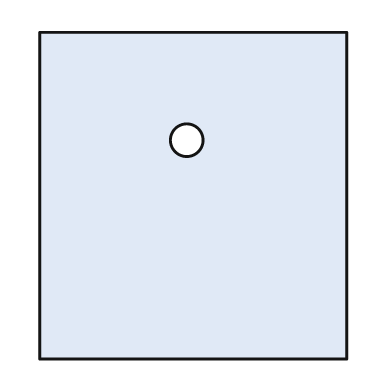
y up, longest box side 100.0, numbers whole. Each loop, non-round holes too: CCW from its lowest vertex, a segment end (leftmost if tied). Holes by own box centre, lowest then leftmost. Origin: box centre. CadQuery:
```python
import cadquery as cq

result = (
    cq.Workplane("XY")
    .moveTo(-47.0, -50.0)
    .lineTo(47.0, -50.0)
    .lineTo(47.0, 50.0)
    .lineTo(-47.0, 50.0)
    .close()
    .moveTo(-2.0, 17.0)
    .circle(5.0)
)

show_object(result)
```